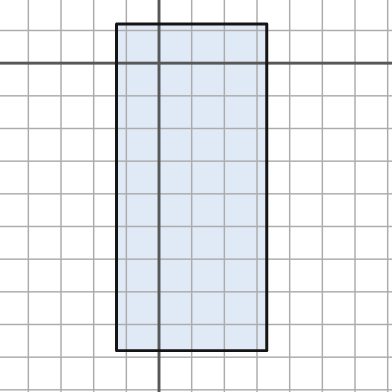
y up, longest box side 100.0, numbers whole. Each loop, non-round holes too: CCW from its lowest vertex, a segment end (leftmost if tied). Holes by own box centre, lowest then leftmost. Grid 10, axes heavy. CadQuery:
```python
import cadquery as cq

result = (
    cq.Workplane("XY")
    .moveTo(-13.0, -88.0)
    .lineTo(33.0, -88.0)
    .lineTo(33.0, 12.0)
    .lineTo(-13.0, 12.0)
    .close()
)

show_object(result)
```